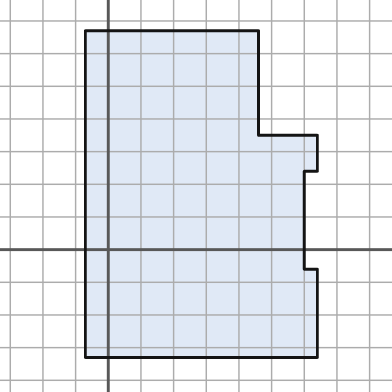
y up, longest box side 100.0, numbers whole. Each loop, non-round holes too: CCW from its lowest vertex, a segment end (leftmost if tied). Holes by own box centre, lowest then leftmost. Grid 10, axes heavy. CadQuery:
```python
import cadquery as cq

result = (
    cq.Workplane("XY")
    .moveTo(-7.0, -33.0)
    .lineTo(64.0, -33.0)
    .lineTo(64.0, -6.0)
    .lineTo(60.0, -6.0)
    .lineTo(60.0, 24.0)
    .lineTo(64.0, 24.0)
    .lineTo(64.0, 35.0)
    .lineTo(46.0, 35.0)
    .lineTo(46.0, 67.0)
    .lineTo(-7.0, 67.0)
    .close()
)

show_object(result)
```